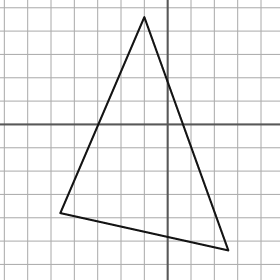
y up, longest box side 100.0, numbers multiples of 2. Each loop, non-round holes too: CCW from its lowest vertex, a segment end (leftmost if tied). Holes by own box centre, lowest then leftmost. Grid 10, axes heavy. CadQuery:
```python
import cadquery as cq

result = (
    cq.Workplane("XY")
    .moveTo(26.0, -54.0)
    .lineTo(-10.0, 46.0)
    .lineTo(-46.0, -38.0)
    .close()
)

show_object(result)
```